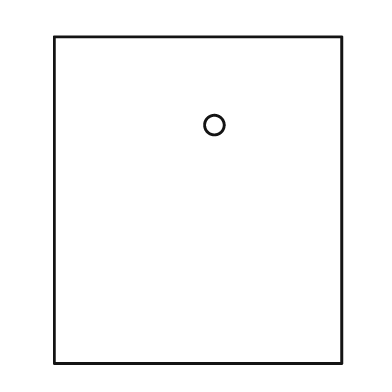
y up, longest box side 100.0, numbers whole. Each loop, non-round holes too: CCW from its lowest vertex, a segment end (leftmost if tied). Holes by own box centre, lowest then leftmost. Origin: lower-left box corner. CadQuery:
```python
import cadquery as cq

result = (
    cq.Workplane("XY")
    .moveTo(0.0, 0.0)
    .lineTo(88.0, 0.0)
    .lineTo(88.0, 100.0)
    .lineTo(0.0, 100.0)
    .close()
    .moveTo(49.0, 73.0)
    .circle(3.0)
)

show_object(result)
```